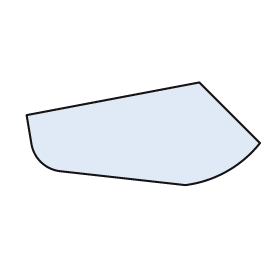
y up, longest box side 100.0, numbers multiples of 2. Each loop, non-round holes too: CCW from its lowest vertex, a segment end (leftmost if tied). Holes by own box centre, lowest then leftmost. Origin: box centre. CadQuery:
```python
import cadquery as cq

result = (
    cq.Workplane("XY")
    .moveTo(18.0, -22.0)
    .threePointArc((36.0, -16.0), (50.0, -4.0))
    .lineTo(24.0, 22.0)
    .lineTo(-50.0, 8.0)
    .lineTo(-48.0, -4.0)
    .threePointArc((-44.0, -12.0), (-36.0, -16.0))
    .close()
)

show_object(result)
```